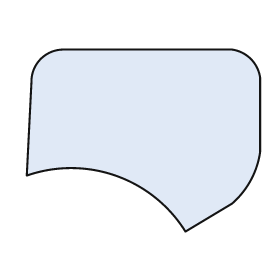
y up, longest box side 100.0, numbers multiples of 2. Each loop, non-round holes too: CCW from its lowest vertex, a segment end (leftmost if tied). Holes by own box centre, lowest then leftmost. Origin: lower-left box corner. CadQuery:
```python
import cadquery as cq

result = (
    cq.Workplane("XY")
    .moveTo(68.0, 0.0)
    .lineTo(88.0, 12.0)
    .threePointArc((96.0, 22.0), (100.0, 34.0))
    .lineTo(100.0, 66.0)
    .threePointArc((96.0, 74.0), (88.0, 78.0))
    .lineTo(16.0, 78.0)
    .threePointArc((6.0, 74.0), (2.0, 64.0))
    .lineTo(0.0, 24.0)
    .threePointArc((38.0, 24.0), (68.0, 0.0))
    .close()
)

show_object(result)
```